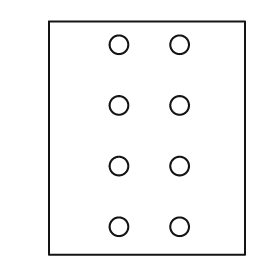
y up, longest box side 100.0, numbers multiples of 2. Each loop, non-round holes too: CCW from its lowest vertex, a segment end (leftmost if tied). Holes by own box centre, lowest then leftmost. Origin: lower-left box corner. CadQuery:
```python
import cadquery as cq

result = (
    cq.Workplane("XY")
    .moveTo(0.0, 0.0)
    .lineTo(84.0, 0.0)
    .lineTo(84.0, 100.0)
    .lineTo(0.0, 100.0)
    .close()
    .moveTo(30.0, 12.0)
    .circle(4.0)
    .moveTo(56.0, 12.0)
    .circle(4.0)
    .moveTo(30.0, 38.0)
    .circle(4.0)
    .moveTo(56.0, 38.0)
    .circle(4.0)
    .moveTo(30.0, 64.0)
    .circle(4.0)
    .moveTo(56.0, 64.0)
    .circle(4.0)
    .moveTo(30.0, 90.0)
    .circle(4.0)
    .moveTo(56.0, 90.0)
    .circle(4.0)
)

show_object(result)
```